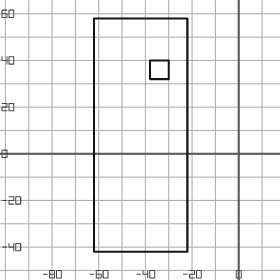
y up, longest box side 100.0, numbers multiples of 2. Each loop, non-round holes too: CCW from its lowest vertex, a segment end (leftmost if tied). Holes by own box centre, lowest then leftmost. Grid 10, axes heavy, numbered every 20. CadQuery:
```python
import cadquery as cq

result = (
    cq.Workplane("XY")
    .moveTo(-62.0, -42.0)
    .lineTo(-22.0, -42.0)
    .lineTo(-22.0, 58.0)
    .lineTo(-62.0, 58.0)
    .close()
    .moveTo(-38.0, 32.0)
    .lineTo(-30.0, 32.0)
    .lineTo(-30.0, 40.0)
    .lineTo(-38.0, 40.0)
    .close()
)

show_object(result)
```